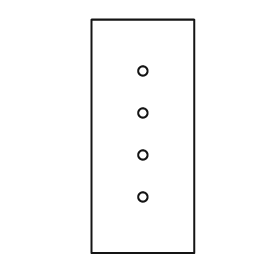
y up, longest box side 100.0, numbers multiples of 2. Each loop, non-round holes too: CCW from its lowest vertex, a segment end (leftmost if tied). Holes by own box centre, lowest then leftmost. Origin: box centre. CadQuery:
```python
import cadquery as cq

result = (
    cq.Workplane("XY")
    .moveTo(-22.0, -50.0)
    .lineTo(22.0, -50.0)
    .lineTo(22.0, 50.0)
    .lineTo(-22.0, 50.0)
    .close()
    .moveTo(0.0, -26.0)
    .circle(2.0)
    .moveTo(0.0, -8.0)
    .circle(2.0)
    .moveTo(0.0, 10.0)
    .circle(2.0)
    .moveTo(0.0, 28.0)
    .circle(2.0)
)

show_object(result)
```